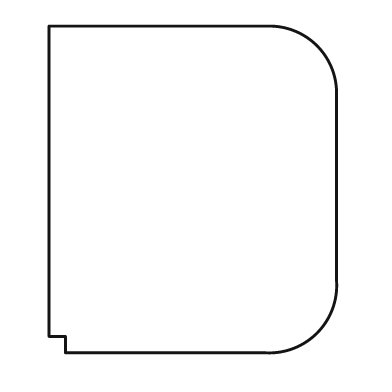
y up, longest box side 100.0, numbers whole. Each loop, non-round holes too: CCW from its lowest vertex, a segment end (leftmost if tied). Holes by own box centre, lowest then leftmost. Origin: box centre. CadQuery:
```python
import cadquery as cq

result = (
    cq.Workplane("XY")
    .moveTo(-39.0, -50.0)
    .lineTo(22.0, -50.0)
    .threePointArc((38.0, -44.0), (44.0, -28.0))
    .lineTo(44.0, 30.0)
    .threePointArc((38.0, 44.0), (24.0, 50.0))
    .lineTo(-44.0, 50.0)
    .lineTo(-44.0, -45.0)
    .lineTo(-39.0, -45.0)
    .close()
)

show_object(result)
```